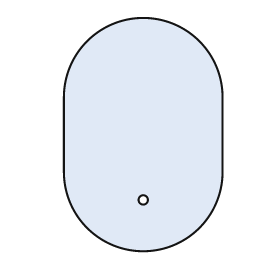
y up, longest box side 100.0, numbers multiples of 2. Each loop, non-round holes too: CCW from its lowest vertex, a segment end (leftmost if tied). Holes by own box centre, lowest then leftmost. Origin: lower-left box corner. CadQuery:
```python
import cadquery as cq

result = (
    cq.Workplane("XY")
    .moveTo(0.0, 34.0)
    .threePointArc((34.0, 0.0), (68.0, 34.0))
    .lineTo(68.0, 66.0)
    .threePointArc((34.0, 100.0), (0.0, 66.0))
    .close()
    .moveTo(34.0, 22.0)
    .circle(2.0)
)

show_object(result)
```